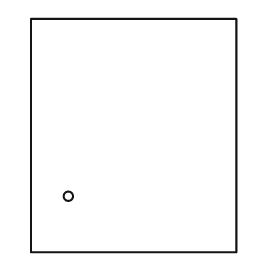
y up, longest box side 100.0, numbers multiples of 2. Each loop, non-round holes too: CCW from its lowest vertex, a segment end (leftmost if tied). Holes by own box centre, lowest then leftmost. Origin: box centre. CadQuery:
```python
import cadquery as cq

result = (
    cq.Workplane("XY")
    .moveTo(-44.0, -50.0)
    .lineTo(44.0, -50.0)
    .lineTo(44.0, 50.0)
    .lineTo(-44.0, 50.0)
    .close()
    .moveTo(-28.0, -26.0)
    .circle(2.0)
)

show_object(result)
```